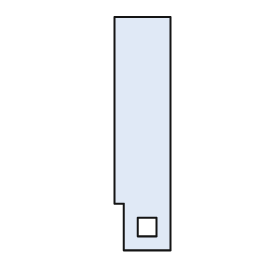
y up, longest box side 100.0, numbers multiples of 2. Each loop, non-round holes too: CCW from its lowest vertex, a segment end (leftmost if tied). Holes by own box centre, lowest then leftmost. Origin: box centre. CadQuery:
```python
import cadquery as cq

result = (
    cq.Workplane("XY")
    .moveTo(-8.0, -50.0)
    .lineTo(12.0, -50.0)
    .lineTo(12.0, 50.0)
    .lineTo(-12.0, 50.0)
    .lineTo(-12.0, -30.0)
    .lineTo(-8.0, -30.0)
    .close()
    .moveTo(-2.0, -44.0)
    .lineTo(6.0, -44.0)
    .lineTo(6.0, -36.0)
    .lineTo(-2.0, -36.0)
    .close()
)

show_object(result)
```